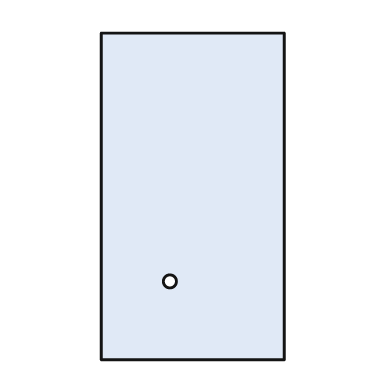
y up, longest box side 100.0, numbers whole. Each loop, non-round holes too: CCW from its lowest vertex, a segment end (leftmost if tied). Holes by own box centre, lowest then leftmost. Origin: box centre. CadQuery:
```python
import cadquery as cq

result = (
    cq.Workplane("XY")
    .moveTo(-28.0, -50.0)
    .lineTo(28.0, -50.0)
    .lineTo(28.0, 50.0)
    .lineTo(-28.0, 50.0)
    .close()
    .moveTo(-7.0, -26.0)
    .circle(2.0)
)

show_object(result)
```